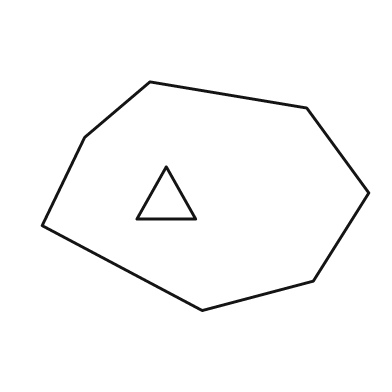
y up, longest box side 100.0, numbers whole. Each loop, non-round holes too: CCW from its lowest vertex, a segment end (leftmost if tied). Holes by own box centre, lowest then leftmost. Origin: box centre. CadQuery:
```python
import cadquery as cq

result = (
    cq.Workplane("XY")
    .moveTo(-1.0, -35.0)
    .lineTo(33.0, -26.0)
    .lineTo(50.0, 1.0)
    .lineTo(31.0, 27.0)
    .lineTo(-17.0, 35.0)
    .lineTo(-37.0, 18.0)
    .lineTo(-50.0, -9.0)
    .close()
    .moveTo(-21.0, -7.0)
    .lineTo(-3.0, -7.0)
    .lineTo(-12.0, 9.0)
    .close()
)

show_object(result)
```